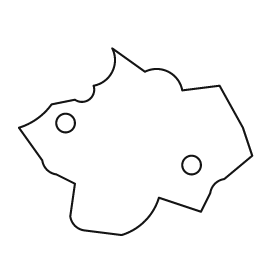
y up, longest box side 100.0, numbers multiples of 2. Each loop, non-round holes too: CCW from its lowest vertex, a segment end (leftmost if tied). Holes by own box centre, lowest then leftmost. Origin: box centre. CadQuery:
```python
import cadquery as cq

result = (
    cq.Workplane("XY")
    .moveTo(-6.0, -40.0)
    .threePointArc((4.0, -34.0), (10.0, -24.0))
    .lineTo(28.0, -30.0)
    .lineTo(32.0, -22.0)
    .threePointArc((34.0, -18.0), (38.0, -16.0))
    .lineTo(50.0, -6.0)
    .lineTo(46.0, 6.0)
    .lineTo(36.0, 24.0)
    .lineTo(20.0, 22.0)
    .threePointArc((14.0, 30.0), (4.0, 30.0))
    .lineTo(-10.0, 40.0)
    .threePointArc((-10.0, 30.0), (-18.0, 24.0))
    .threePointArc((-20.0, 18.0), (-26.0, 18.0))
    .lineTo(-36.0, 16.0)
    .threePointArc((-42.0, 10.0), (-50.0, 6.0))
    .lineTo(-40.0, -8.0)
    .threePointArc((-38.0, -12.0), (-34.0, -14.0))
    .lineTo(-26.0, -18.0)
    .lineTo(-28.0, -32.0)
    .threePointArc((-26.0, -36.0), (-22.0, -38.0))
    .close()
    .moveTo(24.0, -10.0)
    .circle(4.0)
    .moveTo(-30.0, 8.0)
    .circle(4.0)
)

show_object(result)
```